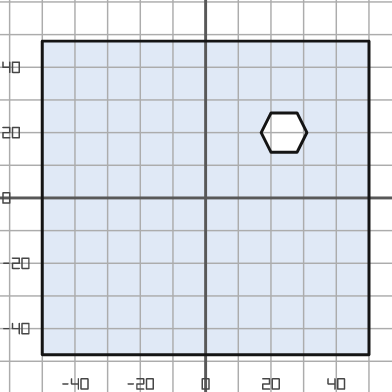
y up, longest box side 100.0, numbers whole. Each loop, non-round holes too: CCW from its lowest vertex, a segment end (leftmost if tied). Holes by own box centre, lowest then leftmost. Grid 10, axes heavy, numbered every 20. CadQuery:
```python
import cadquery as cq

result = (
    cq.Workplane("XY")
    .moveTo(-50.0, -48.0)
    .lineTo(50.0, -48.0)
    .lineTo(50.0, 48.0)
    .lineTo(-50.0, 48.0)
    .close()
    .moveTo(20.0, 14.0)
    .lineTo(28.0, 14.0)
    .lineTo(31.0, 20.0)
    .lineTo(28.0, 26.0)
    .lineTo(20.0, 26.0)
    .lineTo(17.0, 20.0)
    .close()
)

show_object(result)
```